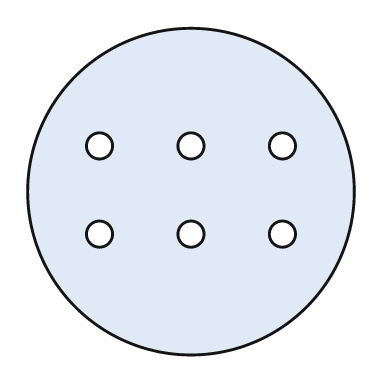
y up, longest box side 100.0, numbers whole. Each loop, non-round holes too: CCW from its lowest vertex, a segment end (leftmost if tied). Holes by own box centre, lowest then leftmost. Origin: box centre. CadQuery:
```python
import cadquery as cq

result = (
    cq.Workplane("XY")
    .moveTo(0.0, 0.0)
    .circle(50.0)
    .moveTo(-28.0, -13.0)
    .circle(4.0)
    .moveTo(0.0, -13.0)
    .circle(4.0)
    .moveTo(28.0, -13.0)
    .circle(4.0)
    .moveTo(-28.0, 14.0)
    .circle(4.0)
    .moveTo(0.0, 14.0)
    .circle(4.0)
    .moveTo(28.0, 14.0)
    .circle(4.0)
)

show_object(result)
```